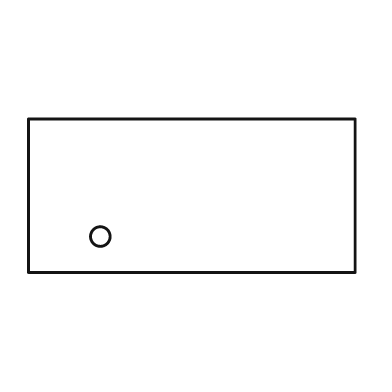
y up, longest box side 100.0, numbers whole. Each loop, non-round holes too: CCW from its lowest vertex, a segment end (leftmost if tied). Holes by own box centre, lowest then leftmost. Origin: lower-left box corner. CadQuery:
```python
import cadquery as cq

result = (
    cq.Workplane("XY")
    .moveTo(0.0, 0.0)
    .lineTo(100.0, 0.0)
    .lineTo(100.0, 47.0)
    .lineTo(0.0, 47.0)
    .close()
    .moveTo(22.0, 11.0)
    .circle(3.0)
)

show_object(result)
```